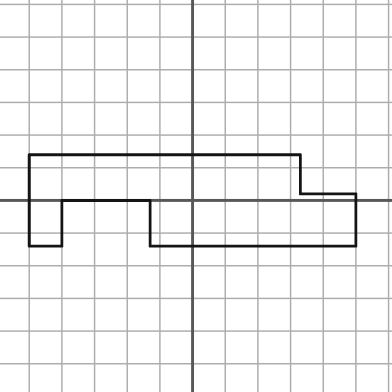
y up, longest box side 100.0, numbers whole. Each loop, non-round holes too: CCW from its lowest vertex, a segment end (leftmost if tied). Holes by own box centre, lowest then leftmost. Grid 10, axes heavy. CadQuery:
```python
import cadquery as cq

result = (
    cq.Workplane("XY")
    .moveTo(-50.0, -14.0)
    .lineTo(-40.0, -14.0)
    .lineTo(-40.0, 0.0)
    .lineTo(-13.0, 0.0)
    .lineTo(-13.0, -14.0)
    .lineTo(50.0, -14.0)
    .lineTo(50.0, 2.0)
    .lineTo(33.0, 2.0)
    .lineTo(33.0, 14.0)
    .lineTo(-50.0, 14.0)
    .close()
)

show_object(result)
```